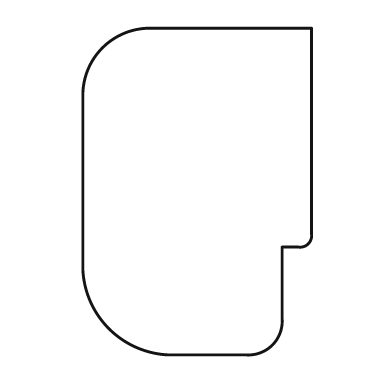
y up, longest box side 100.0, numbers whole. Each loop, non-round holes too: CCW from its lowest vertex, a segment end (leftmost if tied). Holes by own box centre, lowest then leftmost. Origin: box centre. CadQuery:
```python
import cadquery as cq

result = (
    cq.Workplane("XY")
    .moveTo(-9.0, -50.0)
    .lineTo(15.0, -50.0)
    .threePointArc((23.0, -47.0), (26.0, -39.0))
    .lineTo(26.0, -17.0)
    .lineTo(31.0, -17.0)
    .threePointArc((34.0, -16.0), (35.0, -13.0))
    .lineTo(35.0, 50.0)
    .lineTo(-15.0, 50.0)
    .threePointArc((-29.0, 44.0), (-35.0, 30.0))
    .lineTo(-35.0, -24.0)
    .threePointArc((-27.0, -42.0), (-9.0, -50.0))
    .close()
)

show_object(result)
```